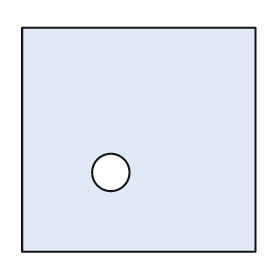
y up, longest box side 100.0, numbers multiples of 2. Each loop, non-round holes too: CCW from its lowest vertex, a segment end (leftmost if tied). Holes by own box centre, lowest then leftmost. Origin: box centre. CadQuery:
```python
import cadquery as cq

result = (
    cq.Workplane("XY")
    .moveTo(-50.0, -48.0)
    .lineTo(50.0, -48.0)
    .lineTo(50.0, 48.0)
    .lineTo(-50.0, 48.0)
    .close()
    .moveTo(-12.0, -14.0)
    .circle(8.0)
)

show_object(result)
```